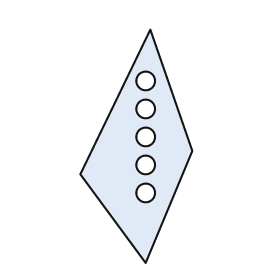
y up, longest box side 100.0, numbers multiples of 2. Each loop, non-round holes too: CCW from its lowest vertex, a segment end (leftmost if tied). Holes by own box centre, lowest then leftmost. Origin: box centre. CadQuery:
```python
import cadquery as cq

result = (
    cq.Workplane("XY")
    .moveTo(4.0, -50.0)
    .lineTo(24.0, -2.0)
    .lineTo(6.0, 50.0)
    .lineTo(-24.0, -12.0)
    .close()
    .moveTo(4.0, -20.0)
    .circle(4.0)
    .moveTo(4.0, -8.0)
    .circle(4.0)
    .moveTo(4.0, 4.0)
    .circle(4.0)
    .moveTo(4.0, 16.0)
    .circle(4.0)
    .moveTo(4.0, 28.0)
    .circle(4.0)
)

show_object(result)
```